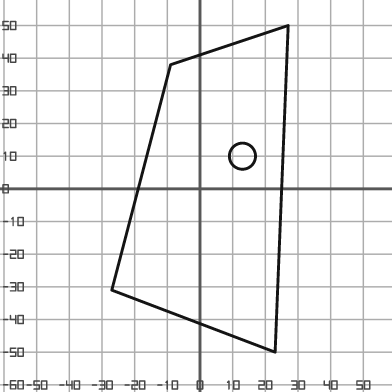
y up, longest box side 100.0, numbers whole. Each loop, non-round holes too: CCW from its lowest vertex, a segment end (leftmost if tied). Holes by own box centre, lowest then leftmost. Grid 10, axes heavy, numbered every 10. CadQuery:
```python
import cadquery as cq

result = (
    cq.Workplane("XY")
    .moveTo(23.0, -50.0)
    .lineTo(27.0, 50.0)
    .lineTo(-9.0, 38.0)
    .lineTo(-27.0, -31.0)
    .close()
    .moveTo(13.0, 10.0)
    .circle(4.0)
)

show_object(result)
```